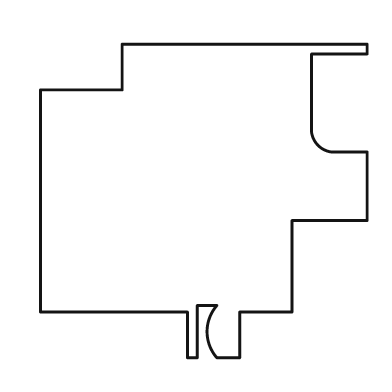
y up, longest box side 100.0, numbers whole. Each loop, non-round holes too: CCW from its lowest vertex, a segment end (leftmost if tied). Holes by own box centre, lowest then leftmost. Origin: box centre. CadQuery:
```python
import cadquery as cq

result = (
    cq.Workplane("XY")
    .moveTo(-5.0, -48.0)
    .lineTo(-2.0, -48.0)
    .lineTo(-2.0, -32.0)
    .lineTo(4.0, -32.0)
    .threePointArc((1.0, -40.0), (4.0, -48.0))
    .lineTo(11.0, -48.0)
    .lineTo(11.0, -34.0)
    .lineTo(27.0, -34.0)
    .lineTo(27.0, -6.0)
    .lineTo(50.0, -6.0)
    .lineTo(50.0, 15.0)
    .lineTo(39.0, 15.0)
    .threePointArc((35.0, 17.0), (33.0, 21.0))
    .lineTo(33.0, 45.0)
    .lineTo(50.0, 45.0)
    .lineTo(50.0, 48.0)
    .lineTo(-25.0, 48.0)
    .lineTo(-25.0, 34.0)
    .lineTo(-50.0, 34.0)
    .lineTo(-50.0, -34.0)
    .lineTo(-5.0, -34.0)
    .close()
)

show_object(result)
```